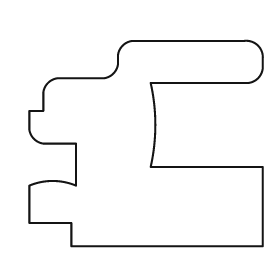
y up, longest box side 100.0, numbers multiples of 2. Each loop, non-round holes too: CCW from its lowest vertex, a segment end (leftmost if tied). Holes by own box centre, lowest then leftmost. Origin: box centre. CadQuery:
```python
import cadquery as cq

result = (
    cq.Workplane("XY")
    .moveTo(-32.0, -44.0)
    .lineTo(50.0, -44.0)
    .lineTo(50.0, -10.0)
    .lineTo(2.0, -10.0)
    .threePointArc((4.0, 8.0), (2.0, 26.0))
    .lineTo(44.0, 26.0)
    .threePointArc((48.0, 28.0), (50.0, 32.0))
    .lineTo(50.0, 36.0)
    .threePointArc((48.0, 42.0), (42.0, 44.0))
    .lineTo(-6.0, 44.0)
    .threePointArc((-10.0, 42.0), (-12.0, 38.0))
    .lineTo(-12.0, 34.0)
    .threePointArc((-14.0, 30.0), (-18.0, 28.0))
    .lineTo(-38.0, 28.0)
    .threePointArc((-42.0, 26.0), (-44.0, 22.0))
    .lineTo(-44.0, 14.0)
    .lineTo(-50.0, 14.0)
    .lineTo(-50.0, 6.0)
    .threePointArc((-48.0, 2.0), (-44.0, 0.0))
    .lineTo(-30.0, 0.0)
    .lineTo(-30.0, -18.0)
    .threePointArc((-40.0, -16.0), (-50.0, -18.0))
    .lineTo(-50.0, -34.0)
    .lineTo(-32.0, -34.0)
    .close()
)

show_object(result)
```